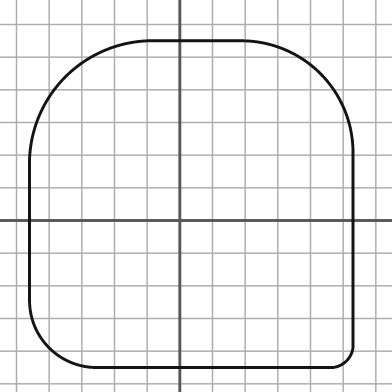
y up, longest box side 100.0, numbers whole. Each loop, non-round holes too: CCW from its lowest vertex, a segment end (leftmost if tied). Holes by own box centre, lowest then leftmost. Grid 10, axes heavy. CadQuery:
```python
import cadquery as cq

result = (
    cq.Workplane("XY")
    .moveTo(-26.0, -45.0)
    .lineTo(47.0, -45.0)
    .threePointArc((51.0, -43.0), (53.0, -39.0))
    .lineTo(53.0, 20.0)
    .threePointArc((43.0, 45.0), (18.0, 55.0))
    .lineTo(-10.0, 55.0)
    .threePointArc((-35.0, 44.0), (-46.0, 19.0))
    .lineTo(-46.0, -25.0)
    .threePointArc((-40.0, -39.0), (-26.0, -45.0))
    .close()
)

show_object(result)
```